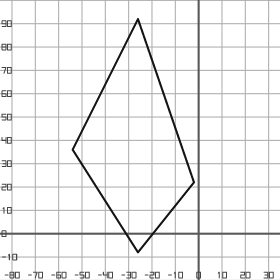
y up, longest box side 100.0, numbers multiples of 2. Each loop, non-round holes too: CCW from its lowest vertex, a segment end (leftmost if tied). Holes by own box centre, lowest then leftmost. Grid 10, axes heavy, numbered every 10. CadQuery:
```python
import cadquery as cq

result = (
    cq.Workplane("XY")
    .moveTo(-26.0, -8.0)
    .lineTo(-2.0, 22.0)
    .lineTo(-26.0, 92.0)
    .lineTo(-54.0, 36.0)
    .close()
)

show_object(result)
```